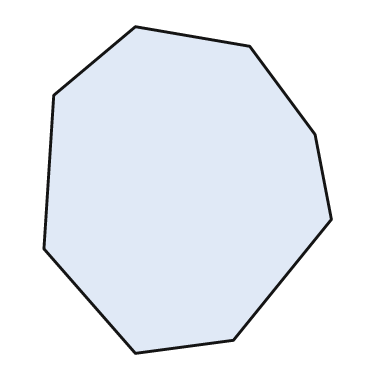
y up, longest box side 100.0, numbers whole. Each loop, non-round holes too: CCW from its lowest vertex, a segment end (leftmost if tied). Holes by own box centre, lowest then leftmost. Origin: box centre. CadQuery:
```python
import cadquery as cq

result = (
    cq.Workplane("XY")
    .moveTo(-16.0, -50.0)
    .lineTo(14.0, -46.0)
    .lineTo(44.0, -9.0)
    .lineTo(39.0, 17.0)
    .lineTo(19.0, 44.0)
    .lineTo(-16.0, 50.0)
    .lineTo(-41.0, 29.0)
    .lineTo(-44.0, -18.0)
    .close()
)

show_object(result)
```